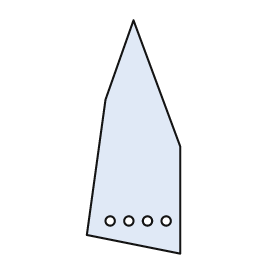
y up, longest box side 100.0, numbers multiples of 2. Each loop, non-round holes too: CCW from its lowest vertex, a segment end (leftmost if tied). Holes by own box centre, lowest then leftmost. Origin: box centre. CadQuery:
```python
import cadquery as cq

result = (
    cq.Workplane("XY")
    .moveTo(20.0, -50.0)
    .lineTo(20.0, -4.0)
    .lineTo(0.0, 50.0)
    .lineTo(-12.0, 16.0)
    .lineTo(-20.0, -42.0)
    .close()
    .moveTo(-10.0, -36.0)
    .circle(2.0)
    .moveTo(-2.0, -36.0)
    .circle(2.0)
    .moveTo(6.0, -36.0)
    .circle(2.0)
    .moveTo(14.0, -36.0)
    .circle(2.0)
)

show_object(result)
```